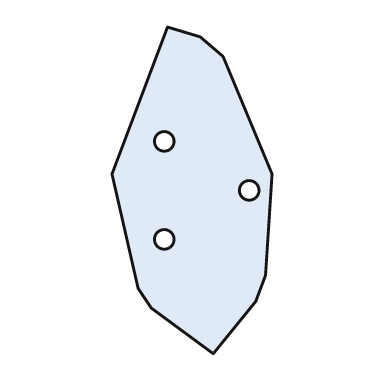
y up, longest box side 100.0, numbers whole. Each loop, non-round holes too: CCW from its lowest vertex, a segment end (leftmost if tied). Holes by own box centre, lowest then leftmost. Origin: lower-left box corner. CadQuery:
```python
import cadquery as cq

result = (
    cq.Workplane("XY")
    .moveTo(31.0, 0.0)
    .lineTo(44.0, 16.0)
    .lineTo(47.0, 24.0)
    .lineTo(49.0, 55.0)
    .lineTo(34.0, 91.0)
    .lineTo(27.0, 97.0)
    .lineTo(17.0, 100.0)
    .lineTo(0.0, 55.0)
    .lineTo(8.0, 20.0)
    .lineTo(12.0, 14.0)
    .close()
    .moveTo(16.0, 35.0)
    .circle(3.0)
    .moveTo(42.0, 50.0)
    .circle(3.0)
    .moveTo(16.0, 65.0)
    .circle(3.0)
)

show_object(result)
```